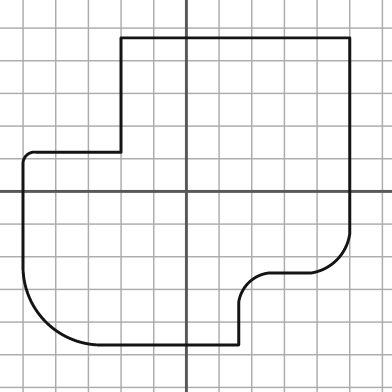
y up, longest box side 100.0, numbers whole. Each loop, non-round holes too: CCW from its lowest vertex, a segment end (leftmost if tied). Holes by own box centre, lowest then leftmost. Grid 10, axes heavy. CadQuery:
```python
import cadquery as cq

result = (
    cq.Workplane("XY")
    .moveTo(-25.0, -47.0)
    .lineTo(16.0, -47.0)
    .lineTo(16.0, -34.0)
    .threePointArc((19.0, -28.0), (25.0, -25.0))
    .lineTo(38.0, -25.0)
    .threePointArc((46.0, -21.0), (50.0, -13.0))
    .lineTo(50.0, 47.0)
    .lineTo(-20.0, 47.0)
    .lineTo(-20.0, 12.0)
    .lineTo(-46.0, 12.0)
    .threePointArc((-49.0, 11.0), (-50.0, 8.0))
    .lineTo(-50.0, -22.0)
    .threePointArc((-43.0, -40.0), (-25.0, -47.0))
    .close()
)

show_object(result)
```